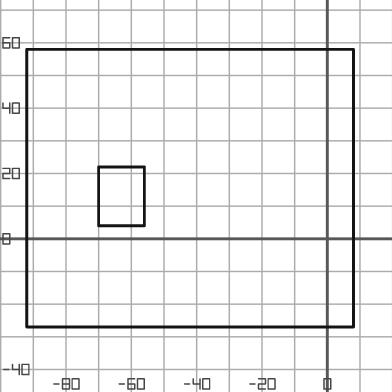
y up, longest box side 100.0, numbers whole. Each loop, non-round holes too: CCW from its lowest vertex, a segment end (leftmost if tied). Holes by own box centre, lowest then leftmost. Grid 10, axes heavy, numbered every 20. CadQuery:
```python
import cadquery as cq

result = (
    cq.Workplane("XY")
    .moveTo(-92.0, -27.0)
    .lineTo(8.0, -27.0)
    .lineTo(8.0, 58.0)
    .lineTo(-92.0, 58.0)
    .close()
    .moveTo(-70.0, 4.0)
    .lineTo(-56.0, 4.0)
    .lineTo(-56.0, 22.0)
    .lineTo(-70.0, 22.0)
    .close()
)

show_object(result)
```